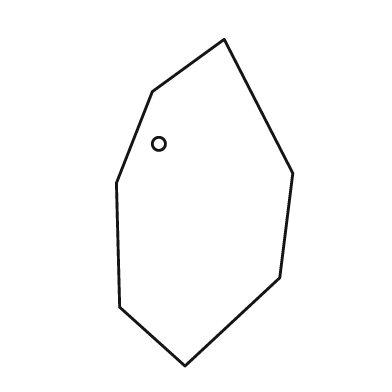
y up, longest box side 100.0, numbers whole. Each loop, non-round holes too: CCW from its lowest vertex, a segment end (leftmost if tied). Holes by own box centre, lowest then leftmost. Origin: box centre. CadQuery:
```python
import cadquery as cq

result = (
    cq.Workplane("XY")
    .moveTo(-6.0, -50.0)
    .lineTo(23.0, -23.0)
    .lineTo(27.0, 9.0)
    .lineTo(6.0, 50.0)
    .lineTo(-16.0, 34.0)
    .lineTo(-27.0, 6.0)
    .lineTo(-26.0, -32.0)
    .close()
    .moveTo(-14.0, 18.0)
    .circle(2.0)
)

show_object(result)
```